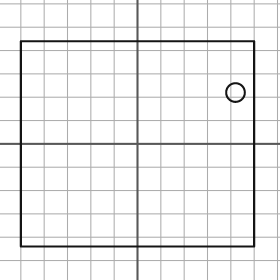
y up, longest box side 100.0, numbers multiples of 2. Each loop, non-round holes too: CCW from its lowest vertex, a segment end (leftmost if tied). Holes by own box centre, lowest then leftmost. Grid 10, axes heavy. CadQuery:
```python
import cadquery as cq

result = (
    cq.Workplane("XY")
    .moveTo(-50.0, -44.0)
    .lineTo(50.0, -44.0)
    .lineTo(50.0, 44.0)
    .lineTo(-50.0, 44.0)
    .close()
    .moveTo(42.0, 22.0)
    .circle(4.0)
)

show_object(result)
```